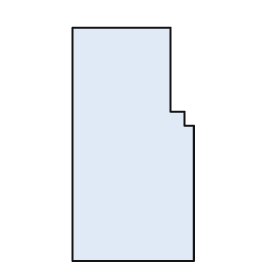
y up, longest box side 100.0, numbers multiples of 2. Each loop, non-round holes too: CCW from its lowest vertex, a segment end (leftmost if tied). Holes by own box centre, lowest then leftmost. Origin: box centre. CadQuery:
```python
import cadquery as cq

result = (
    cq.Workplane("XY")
    .moveTo(-26.0, -50.0)
    .lineTo(26.0, -50.0)
    .lineTo(26.0, 8.0)
    .lineTo(22.0, 8.0)
    .lineTo(22.0, 14.0)
    .lineTo(16.0, 14.0)
    .lineTo(16.0, 50.0)
    .lineTo(-26.0, 50.0)
    .close()
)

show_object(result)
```